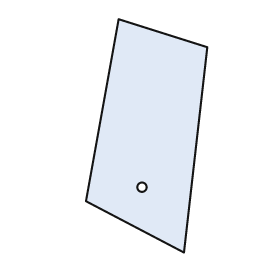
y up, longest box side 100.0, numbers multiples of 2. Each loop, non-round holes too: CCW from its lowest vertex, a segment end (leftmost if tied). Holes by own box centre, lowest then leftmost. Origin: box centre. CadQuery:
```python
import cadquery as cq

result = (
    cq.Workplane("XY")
    .moveTo(16.0, -50.0)
    .lineTo(26.0, 38.0)
    .lineTo(-12.0, 50.0)
    .lineTo(-26.0, -28.0)
    .close()
    .moveTo(-2.0, -22.0)
    .circle(2.0)
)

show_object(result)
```